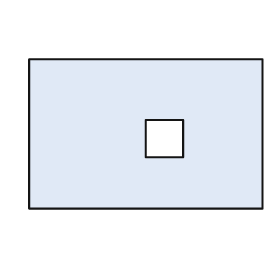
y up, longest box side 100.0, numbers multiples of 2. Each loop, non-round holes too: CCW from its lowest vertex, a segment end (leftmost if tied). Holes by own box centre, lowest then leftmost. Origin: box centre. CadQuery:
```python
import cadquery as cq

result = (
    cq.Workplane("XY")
    .moveTo(-50.0, -32.0)
    .lineTo(50.0, -32.0)
    .lineTo(50.0, 32.0)
    .lineTo(-50.0, 32.0)
    .close()
    .moveTo(0.0, -10.0)
    .lineTo(16.0, -10.0)
    .lineTo(16.0, 6.0)
    .lineTo(0.0, 6.0)
    .close()
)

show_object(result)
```